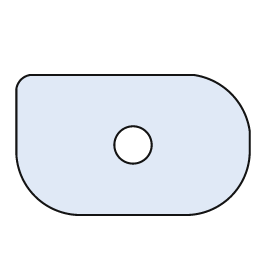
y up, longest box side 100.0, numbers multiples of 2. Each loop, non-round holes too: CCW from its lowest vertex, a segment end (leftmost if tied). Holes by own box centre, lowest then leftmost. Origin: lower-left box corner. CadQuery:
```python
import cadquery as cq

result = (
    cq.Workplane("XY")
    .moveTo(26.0, 0.0)
    .lineTo(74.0, 0.0)
    .threePointArc((92.0, 8.0), (100.0, 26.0))
    .lineTo(100.0, 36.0)
    .threePointArc((92.0, 52.0), (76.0, 60.0))
    .lineTo(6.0, 60.0)
    .threePointArc((2.0, 58.0), (0.0, 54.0))
    .lineTo(0.0, 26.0)
    .threePointArc((8.0, 8.0), (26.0, 0.0))
    .close()
    .moveTo(50.0, 30.0)
    .circle(8.0)
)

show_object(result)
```